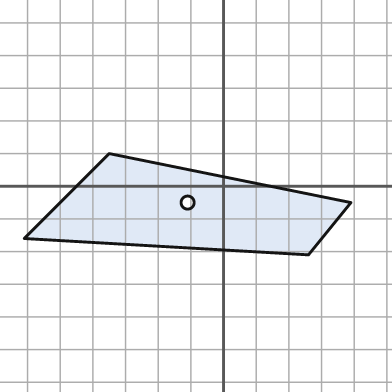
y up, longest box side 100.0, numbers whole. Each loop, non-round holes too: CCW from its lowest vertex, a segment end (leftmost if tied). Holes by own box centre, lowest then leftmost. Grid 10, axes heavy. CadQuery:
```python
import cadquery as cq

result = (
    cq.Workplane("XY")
    .moveTo(26.0, -21.0)
    .lineTo(39.0, -5.0)
    .lineTo(-35.0, 10.0)
    .lineTo(-61.0, -16.0)
    .close()
    .moveTo(-11.0, -5.0)
    .circle(2.0)
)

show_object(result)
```